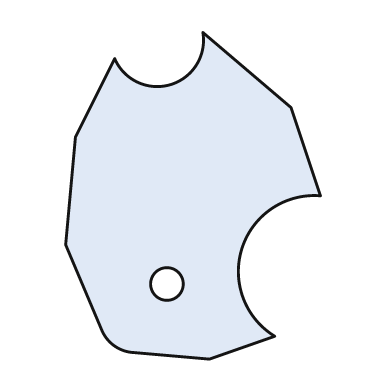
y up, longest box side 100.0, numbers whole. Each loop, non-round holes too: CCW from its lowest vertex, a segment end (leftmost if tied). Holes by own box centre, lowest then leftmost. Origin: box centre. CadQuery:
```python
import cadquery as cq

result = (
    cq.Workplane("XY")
    .moveTo(5.0, -50.0)
    .lineTo(25.0, -43.0)
    .threePointArc((15.0, -16.0), (39.0, 0.0))
    .lineTo(30.0, 27.0)
    .lineTo(3.0, 50.0)
    .threePointArc((-7.0, 34.0), (-24.0, 42.0))
    .lineTo(-36.0, 18.0)
    .lineTo(-39.0, -15.0)
    .lineTo(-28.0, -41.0)
    .threePointArc((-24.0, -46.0), (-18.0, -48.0))
    .close()
    .moveTo(-8.0, -27.0)
    .circle(5.0)
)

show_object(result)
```